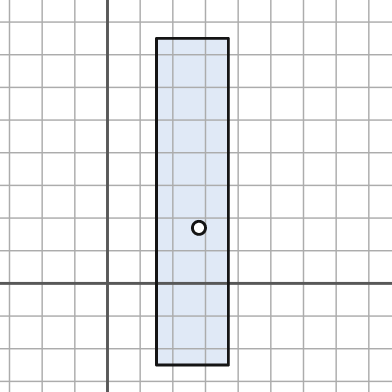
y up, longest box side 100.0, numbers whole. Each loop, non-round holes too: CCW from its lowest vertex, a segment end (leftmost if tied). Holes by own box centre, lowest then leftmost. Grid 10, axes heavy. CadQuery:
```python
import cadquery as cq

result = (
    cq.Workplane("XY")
    .moveTo(15.0, -25.0)
    .lineTo(37.0, -25.0)
    .lineTo(37.0, 75.0)
    .lineTo(15.0, 75.0)
    .close()
    .moveTo(28.0, 17.0)
    .circle(2.0)
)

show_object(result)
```